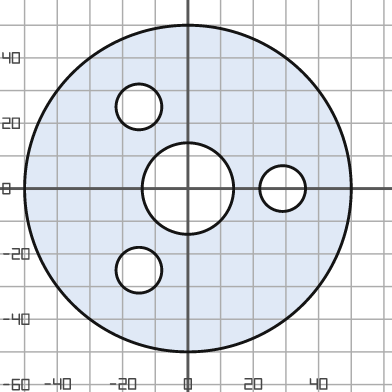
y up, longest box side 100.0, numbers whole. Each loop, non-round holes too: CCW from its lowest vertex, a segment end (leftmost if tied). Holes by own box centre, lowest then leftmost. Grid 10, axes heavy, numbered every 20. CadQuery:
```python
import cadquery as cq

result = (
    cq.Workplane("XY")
    .moveTo(0.0, 0.0)
    .circle(50.0)
    .moveTo(-15.0, -25.0)
    .circle(7.0)
    .moveTo(0.0, 0.0)
    .circle(14.0)
    .moveTo(29.0, 0.0)
    .circle(7.0)
    .moveTo(-15.0, 25.0)
    .circle(7.0)
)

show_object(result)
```